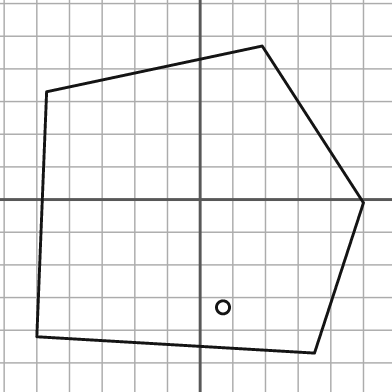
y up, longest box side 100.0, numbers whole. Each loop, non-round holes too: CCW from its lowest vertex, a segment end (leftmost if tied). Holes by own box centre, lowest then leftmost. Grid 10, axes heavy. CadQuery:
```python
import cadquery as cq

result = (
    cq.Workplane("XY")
    .moveTo(35.0, -47.0)
    .lineTo(50.0, -1.0)
    .lineTo(19.0, 47.0)
    .lineTo(-47.0, 33.0)
    .lineTo(-50.0, -42.0)
    .close()
    .moveTo(7.0, -33.0)
    .circle(2.0)
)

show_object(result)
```